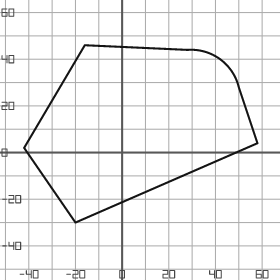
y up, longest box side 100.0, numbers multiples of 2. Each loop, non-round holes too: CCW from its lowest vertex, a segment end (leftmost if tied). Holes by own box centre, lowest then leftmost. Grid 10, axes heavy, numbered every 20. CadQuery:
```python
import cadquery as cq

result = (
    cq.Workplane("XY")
    .moveTo(-20.0, -30.0)
    .lineTo(58.0, 4.0)
    .lineTo(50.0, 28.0)
    .threePointArc((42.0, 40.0), (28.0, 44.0))
    .lineTo(-16.0, 46.0)
    .lineTo(-42.0, 2.0)
    .close()
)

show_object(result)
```